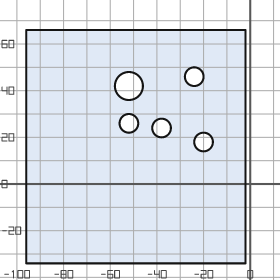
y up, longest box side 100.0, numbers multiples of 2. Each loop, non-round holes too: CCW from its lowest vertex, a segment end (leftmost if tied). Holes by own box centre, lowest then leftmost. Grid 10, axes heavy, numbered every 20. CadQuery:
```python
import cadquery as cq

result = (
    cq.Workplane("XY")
    .moveTo(-96.0, -34.0)
    .lineTo(-2.0, -34.0)
    .lineTo(-2.0, 66.0)
    .lineTo(-96.0, 66.0)
    .close()
    .moveTo(-20.0, 18.0)
    .circle(4.0)
    .moveTo(-38.0, 24.0)
    .circle(4.0)
    .moveTo(-52.0, 26.0)
    .circle(4.0)
    .moveTo(-52.0, 42.0)
    .circle(6.0)
    .moveTo(-24.0, 46.0)
    .circle(4.0)
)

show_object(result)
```